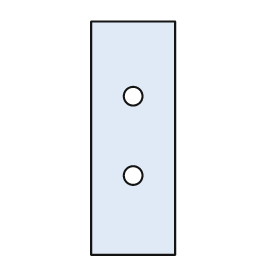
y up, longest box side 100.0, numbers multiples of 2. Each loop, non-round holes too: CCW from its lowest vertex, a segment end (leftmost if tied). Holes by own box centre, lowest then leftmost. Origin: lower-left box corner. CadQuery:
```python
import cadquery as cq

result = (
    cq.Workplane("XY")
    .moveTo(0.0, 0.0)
    .lineTo(36.0, 0.0)
    .lineTo(36.0, 100.0)
    .lineTo(0.0, 100.0)
    .close()
    .moveTo(18.0, 34.0)
    .circle(4.0)
    .moveTo(18.0, 68.0)
    .circle(4.0)
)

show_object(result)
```